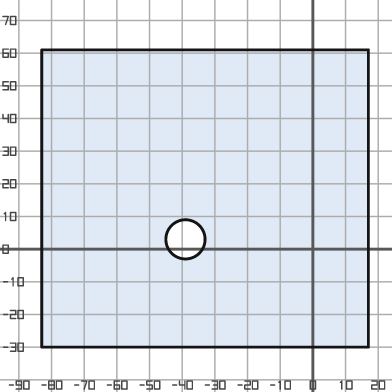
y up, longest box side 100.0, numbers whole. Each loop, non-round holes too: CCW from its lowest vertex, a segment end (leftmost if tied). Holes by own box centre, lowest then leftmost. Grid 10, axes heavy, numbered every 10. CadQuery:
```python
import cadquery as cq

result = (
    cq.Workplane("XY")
    .moveTo(-83.0, -30.0)
    .lineTo(17.0, -30.0)
    .lineTo(17.0, 61.0)
    .lineTo(-83.0, 61.0)
    .close()
    .moveTo(-39.0, 3.0)
    .circle(6.0)
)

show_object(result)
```